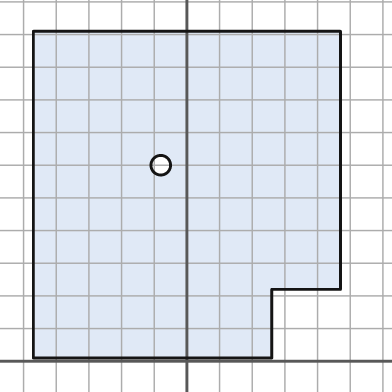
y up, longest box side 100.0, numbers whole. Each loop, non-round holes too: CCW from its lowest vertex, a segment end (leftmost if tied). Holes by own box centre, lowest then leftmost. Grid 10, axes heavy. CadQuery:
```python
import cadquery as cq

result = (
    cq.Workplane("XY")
    .moveTo(-47.0, 1.0)
    .lineTo(26.0, 1.0)
    .lineTo(26.0, 22.0)
    .lineTo(47.0, 22.0)
    .lineTo(47.0, 101.0)
    .lineTo(-47.0, 101.0)
    .close()
    .moveTo(-8.0, 60.0)
    .circle(3.0)
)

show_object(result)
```